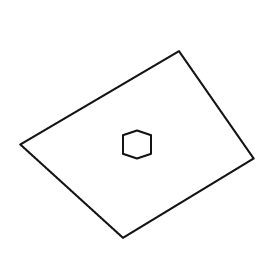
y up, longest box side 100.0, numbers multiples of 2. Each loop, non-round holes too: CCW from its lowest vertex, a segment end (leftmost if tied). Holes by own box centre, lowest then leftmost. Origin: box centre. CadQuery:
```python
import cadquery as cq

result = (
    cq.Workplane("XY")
    .moveTo(-6.0, -40.0)
    .lineTo(50.0, -6.0)
    .lineTo(18.0, 40.0)
    .lineTo(-50.0, 0.0)
    .close()
    .moveTo(0.0, -6.0)
    .lineTo(6.0, -4.0)
    .lineTo(6.0, 4.0)
    .lineTo(0.0, 6.0)
    .lineTo(-6.0, 4.0)
    .lineTo(-6.0, -4.0)
    .close()
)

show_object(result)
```